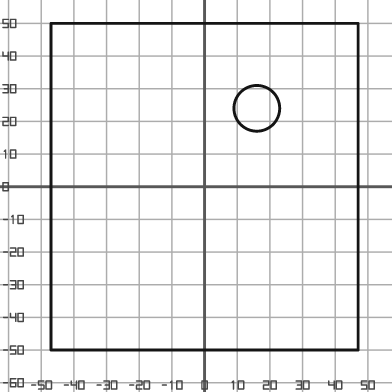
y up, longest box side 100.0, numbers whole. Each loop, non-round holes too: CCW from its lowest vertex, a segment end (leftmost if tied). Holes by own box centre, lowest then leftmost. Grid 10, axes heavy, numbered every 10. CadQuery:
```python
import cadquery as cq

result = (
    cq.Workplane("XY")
    .moveTo(-47.0, -50.0)
    .lineTo(47.0, -50.0)
    .lineTo(47.0, 50.0)
    .lineTo(-47.0, 50.0)
    .close()
    .moveTo(16.0, 24.0)
    .circle(7.0)
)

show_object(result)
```